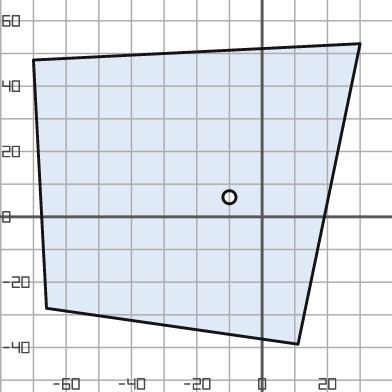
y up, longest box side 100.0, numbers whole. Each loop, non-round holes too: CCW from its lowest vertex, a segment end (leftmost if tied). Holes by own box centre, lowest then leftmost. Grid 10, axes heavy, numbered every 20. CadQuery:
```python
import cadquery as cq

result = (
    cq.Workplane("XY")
    .moveTo(11.0, -39.0)
    .lineTo(30.0, 53.0)
    .lineTo(-70.0, 48.0)
    .lineTo(-66.0, -28.0)
    .close()
    .moveTo(-10.0, 6.0)
    .circle(2.0)
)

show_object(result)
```